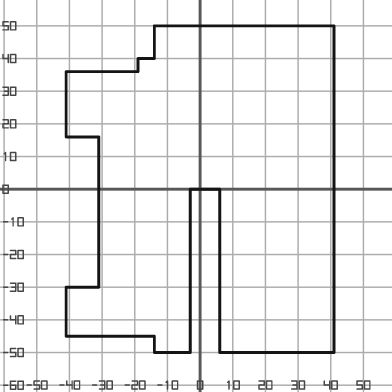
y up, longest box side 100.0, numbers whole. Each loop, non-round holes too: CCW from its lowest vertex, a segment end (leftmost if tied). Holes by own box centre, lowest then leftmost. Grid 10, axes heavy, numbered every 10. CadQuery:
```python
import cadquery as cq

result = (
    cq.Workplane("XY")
    .moveTo(-14.0, -50.0)
    .lineTo(-3.0, -50.0)
    .lineTo(-3.0, 0.0)
    .lineTo(6.0, 0.0)
    .lineTo(6.0, -50.0)
    .lineTo(41.0, -50.0)
    .lineTo(41.0, 50.0)
    .lineTo(-14.0, 50.0)
    .lineTo(-14.0, 40.0)
    .lineTo(-19.0, 40.0)
    .lineTo(-19.0, 36.0)
    .lineTo(-41.0, 36.0)
    .lineTo(-41.0, 16.0)
    .lineTo(-31.0, 16.0)
    .lineTo(-31.0, -30.0)
    .lineTo(-41.0, -30.0)
    .lineTo(-41.0, -45.0)
    .lineTo(-14.0, -45.0)
    .close()
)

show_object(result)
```